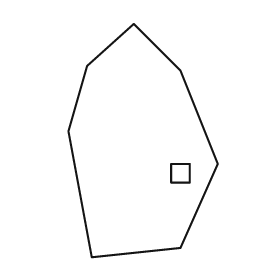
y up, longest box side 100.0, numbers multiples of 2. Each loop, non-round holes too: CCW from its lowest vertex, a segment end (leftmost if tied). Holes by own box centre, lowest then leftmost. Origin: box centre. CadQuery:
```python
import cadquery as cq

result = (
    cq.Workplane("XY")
    .moveTo(-22.0, -50.0)
    .lineTo(16.0, -46.0)
    .lineTo(32.0, -10.0)
    .lineTo(16.0, 30.0)
    .lineTo(-4.0, 50.0)
    .lineTo(-24.0, 32.0)
    .lineTo(-32.0, 4.0)
    .close()
    .moveTo(12.0, -18.0)
    .lineTo(20.0, -18.0)
    .lineTo(20.0, -10.0)
    .lineTo(12.0, -10.0)
    .close()
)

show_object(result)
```